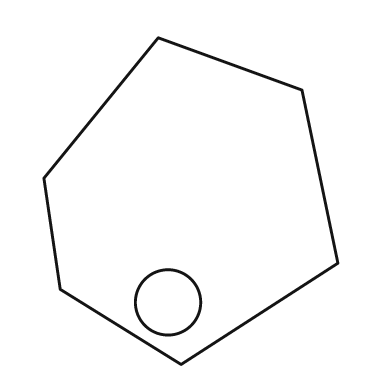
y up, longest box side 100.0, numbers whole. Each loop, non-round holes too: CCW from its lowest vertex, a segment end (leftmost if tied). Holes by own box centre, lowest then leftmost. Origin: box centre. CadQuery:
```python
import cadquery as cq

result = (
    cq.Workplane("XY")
    .moveTo(-3.0, -50.0)
    .lineTo(45.0, -19.0)
    .lineTo(34.0, 34.0)
    .lineTo(-10.0, 50.0)
    .lineTo(-45.0, 7.0)
    .lineTo(-40.0, -27.0)
    .close()
    .moveTo(-7.0, -31.0)
    .circle(10.0)
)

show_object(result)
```